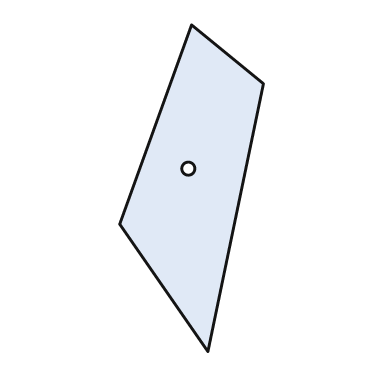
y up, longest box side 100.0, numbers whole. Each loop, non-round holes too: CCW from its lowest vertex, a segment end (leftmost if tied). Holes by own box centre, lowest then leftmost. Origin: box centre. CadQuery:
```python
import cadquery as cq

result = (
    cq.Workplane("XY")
    .moveTo(5.0, -50.0)
    .lineTo(22.0, 32.0)
    .lineTo(0.0, 50.0)
    .lineTo(-22.0, -11.0)
    .close()
    .moveTo(-1.0, 6.0)
    .circle(2.0)
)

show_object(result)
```